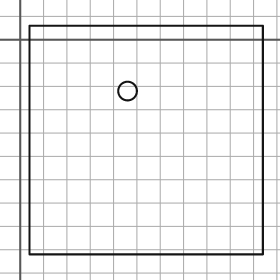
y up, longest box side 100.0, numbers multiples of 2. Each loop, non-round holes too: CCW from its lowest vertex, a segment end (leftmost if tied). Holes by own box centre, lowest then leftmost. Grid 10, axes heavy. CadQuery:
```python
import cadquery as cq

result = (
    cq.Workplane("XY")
    .moveTo(4.0, -92.0)
    .lineTo(104.0, -92.0)
    .lineTo(104.0, 6.0)
    .lineTo(4.0, 6.0)
    .close()
    .moveTo(46.0, -22.0)
    .circle(4.0)
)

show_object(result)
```